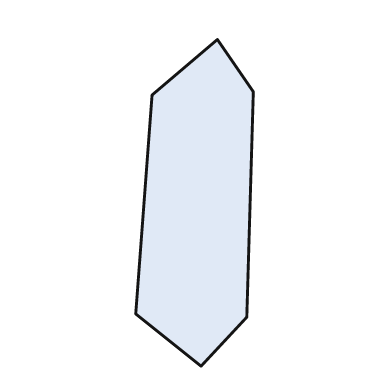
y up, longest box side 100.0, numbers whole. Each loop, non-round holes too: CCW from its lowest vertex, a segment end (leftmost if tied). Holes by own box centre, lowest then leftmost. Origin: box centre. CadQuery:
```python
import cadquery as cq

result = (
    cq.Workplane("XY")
    .moveTo(2.0, -50.0)
    .lineTo(16.0, -35.0)
    .lineTo(18.0, 34.0)
    .lineTo(7.0, 50.0)
    .lineTo(-13.0, 33.0)
    .lineTo(-18.0, -34.0)
    .close()
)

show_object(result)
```